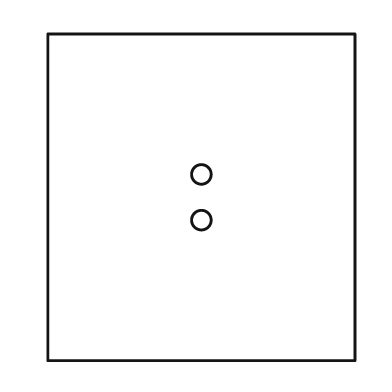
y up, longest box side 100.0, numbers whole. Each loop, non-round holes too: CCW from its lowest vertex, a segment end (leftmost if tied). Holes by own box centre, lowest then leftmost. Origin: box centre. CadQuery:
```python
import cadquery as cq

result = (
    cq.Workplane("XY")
    .moveTo(-47.0, -50.0)
    .lineTo(47.0, -50.0)
    .lineTo(47.0, 50.0)
    .lineTo(-47.0, 50.0)
    .close()
    .moveTo(0.0, -7.0)
    .circle(3.0)
    .moveTo(0.0, 7.0)
    .circle(3.0)
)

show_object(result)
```